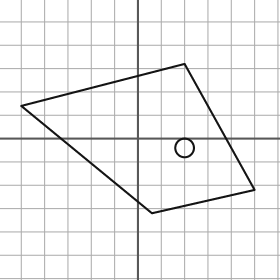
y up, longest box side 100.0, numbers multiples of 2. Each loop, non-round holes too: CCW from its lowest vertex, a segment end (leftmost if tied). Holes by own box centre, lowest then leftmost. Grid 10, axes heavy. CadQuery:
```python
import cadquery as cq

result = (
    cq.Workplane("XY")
    .moveTo(6.0, -32.0)
    .lineTo(50.0, -22.0)
    .lineTo(20.0, 32.0)
    .lineTo(-50.0, 14.0)
    .close()
    .moveTo(20.0, -4.0)
    .circle(4.0)
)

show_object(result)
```